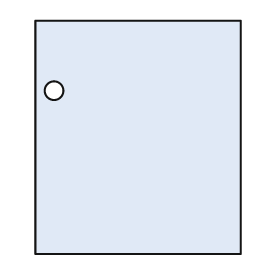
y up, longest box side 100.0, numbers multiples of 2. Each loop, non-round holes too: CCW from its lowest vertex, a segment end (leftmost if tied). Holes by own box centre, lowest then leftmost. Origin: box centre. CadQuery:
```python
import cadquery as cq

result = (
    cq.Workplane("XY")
    .moveTo(-44.0, -50.0)
    .lineTo(44.0, -50.0)
    .lineTo(44.0, 50.0)
    .lineTo(-44.0, 50.0)
    .close()
    .moveTo(-36.0, 20.0)
    .circle(4.0)
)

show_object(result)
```